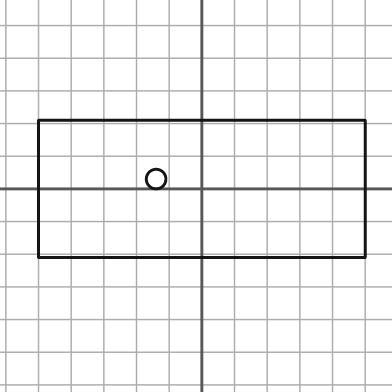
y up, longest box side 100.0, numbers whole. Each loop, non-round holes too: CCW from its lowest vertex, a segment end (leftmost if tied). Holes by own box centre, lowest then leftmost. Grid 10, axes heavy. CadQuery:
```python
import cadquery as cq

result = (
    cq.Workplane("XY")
    .moveTo(-50.0, -21.0)
    .lineTo(50.0, -21.0)
    .lineTo(50.0, 21.0)
    .lineTo(-50.0, 21.0)
    .close()
    .moveTo(-14.0, 3.0)
    .circle(3.0)
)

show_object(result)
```